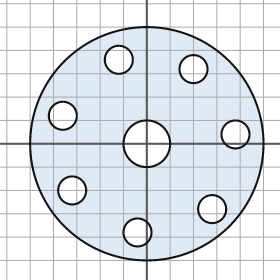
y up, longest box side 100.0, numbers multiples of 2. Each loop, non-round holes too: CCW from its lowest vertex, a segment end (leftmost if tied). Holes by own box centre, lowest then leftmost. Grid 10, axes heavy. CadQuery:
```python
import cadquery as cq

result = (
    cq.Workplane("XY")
    .moveTo(0.0, 0.0)
    .circle(50.0)
    .moveTo(-4.0, -38.0)
    .circle(6.0)
    .moveTo(28.0, -28.0)
    .circle(6.0)
    .moveTo(-32.0, -20.0)
    .circle(6.0)
    .moveTo(0.0, 0.0)
    .circle(10.0)
    .moveTo(38.0, 4.0)
    .circle(6.0)
    .moveTo(-36.0, 12.0)
    .circle(6.0)
    .moveTo(20.0, 32.0)
    .circle(6.0)
    .moveTo(-12.0, 36.0)
    .circle(6.0)
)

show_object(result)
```